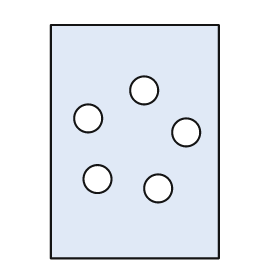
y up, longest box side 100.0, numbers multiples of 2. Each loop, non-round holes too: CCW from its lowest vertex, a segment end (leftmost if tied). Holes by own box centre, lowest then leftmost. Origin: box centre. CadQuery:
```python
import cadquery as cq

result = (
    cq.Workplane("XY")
    .moveTo(-36.0, -50.0)
    .lineTo(36.0, -50.0)
    .lineTo(36.0, 50.0)
    .lineTo(-36.0, 50.0)
    .close()
    .moveTo(10.0, -20.0)
    .circle(6.0)
    .moveTo(-16.0, -16.0)
    .circle(6.0)
    .moveTo(22.0, 4.0)
    .circle(6.0)
    .moveTo(-20.0, 10.0)
    .circle(6.0)
    .moveTo(4.0, 22.0)
    .circle(6.0)
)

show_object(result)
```